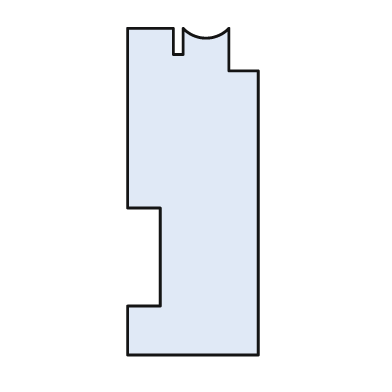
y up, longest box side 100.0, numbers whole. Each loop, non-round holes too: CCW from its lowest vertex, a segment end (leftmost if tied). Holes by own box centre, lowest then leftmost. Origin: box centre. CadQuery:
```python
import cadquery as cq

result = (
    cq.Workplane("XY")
    .moveTo(-20.0, -50.0)
    .lineTo(20.0, -50.0)
    .lineTo(20.0, 37.0)
    .lineTo(11.0, 37.0)
    .lineTo(11.0, 50.0)
    .threePointArc((4.0, 47.0), (-3.0, 50.0))
    .lineTo(-3.0, 42.0)
    .lineTo(-6.0, 42.0)
    .lineTo(-6.0, 50.0)
    .lineTo(-20.0, 50.0)
    .lineTo(-20.0, -5.0)
    .lineTo(-10.0, -5.0)
    .lineTo(-10.0, -35.0)
    .lineTo(-20.0, -35.0)
    .close()
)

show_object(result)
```